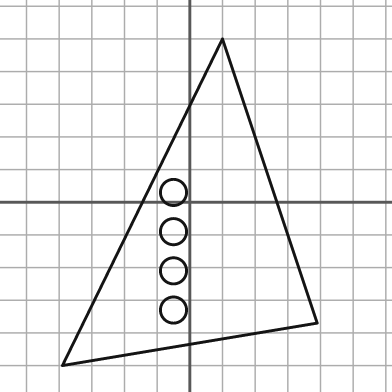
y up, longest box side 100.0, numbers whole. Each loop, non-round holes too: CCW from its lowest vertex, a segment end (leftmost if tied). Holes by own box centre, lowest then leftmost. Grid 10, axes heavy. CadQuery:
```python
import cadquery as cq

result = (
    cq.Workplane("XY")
    .moveTo(-39.0, -50.0)
    .lineTo(39.0, -37.0)
    .lineTo(10.0, 50.0)
    .close()
    .moveTo(-5.0, -33.0)
    .circle(4.0)
    .moveTo(-5.0, -21.0)
    .circle(4.0)
    .moveTo(-5.0, -9.0)
    .circle(4.0)
    .moveTo(-5.0, 3.0)
    .circle(4.0)
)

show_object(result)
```